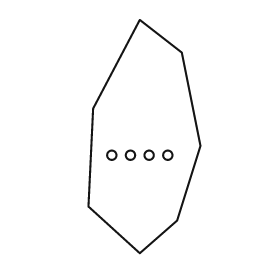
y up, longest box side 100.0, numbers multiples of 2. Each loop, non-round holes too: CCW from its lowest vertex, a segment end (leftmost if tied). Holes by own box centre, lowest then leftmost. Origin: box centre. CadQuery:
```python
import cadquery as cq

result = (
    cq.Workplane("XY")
    .moveTo(-2.0, -50.0)
    .lineTo(14.0, -36.0)
    .lineTo(24.0, -4.0)
    .lineTo(16.0, 36.0)
    .lineTo(-2.0, 50.0)
    .lineTo(-22.0, 12.0)
    .lineTo(-24.0, -30.0)
    .close()
    .moveTo(-14.0, -8.0)
    .circle(2.0)
    .moveTo(-6.0, -8.0)
    .circle(2.0)
    .moveTo(2.0, -8.0)
    .circle(2.0)
    .moveTo(10.0, -8.0)
    .circle(2.0)
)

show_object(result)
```